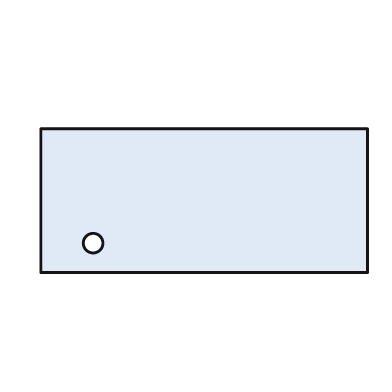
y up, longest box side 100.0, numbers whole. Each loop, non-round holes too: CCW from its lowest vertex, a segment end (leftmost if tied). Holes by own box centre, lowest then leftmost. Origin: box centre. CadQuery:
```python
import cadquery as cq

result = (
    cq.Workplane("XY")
    .moveTo(-50.0, -22.0)
    .lineTo(50.0, -22.0)
    .lineTo(50.0, 22.0)
    .lineTo(-50.0, 22.0)
    .close()
    .moveTo(-34.0, -13.0)
    .circle(3.0)
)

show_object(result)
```